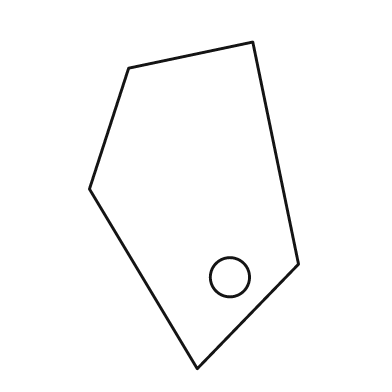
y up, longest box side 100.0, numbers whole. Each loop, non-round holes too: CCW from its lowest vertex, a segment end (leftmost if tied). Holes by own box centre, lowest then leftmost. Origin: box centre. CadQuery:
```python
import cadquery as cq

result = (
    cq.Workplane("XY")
    .moveTo(1.0, -50.0)
    .lineTo(32.0, -18.0)
    .lineTo(18.0, 50.0)
    .lineTo(-20.0, 42.0)
    .lineTo(-32.0, 5.0)
    .close()
    .moveTo(11.0, -22.0)
    .circle(6.0)
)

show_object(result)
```